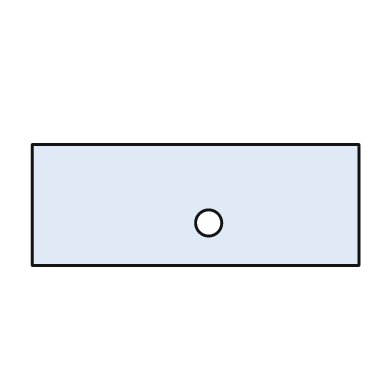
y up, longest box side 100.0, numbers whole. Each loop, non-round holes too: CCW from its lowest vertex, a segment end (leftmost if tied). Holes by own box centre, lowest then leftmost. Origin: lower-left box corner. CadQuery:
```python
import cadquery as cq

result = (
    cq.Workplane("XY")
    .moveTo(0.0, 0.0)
    .lineTo(100.0, 0.0)
    .lineTo(100.0, 37.0)
    .lineTo(0.0, 37.0)
    .close()
    .moveTo(54.0, 13.0)
    .circle(4.0)
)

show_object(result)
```